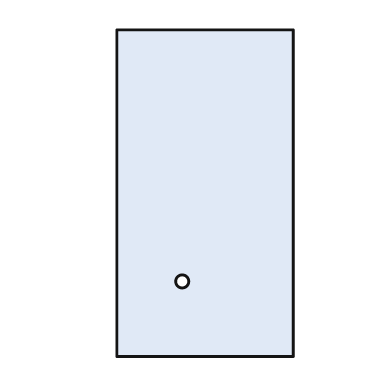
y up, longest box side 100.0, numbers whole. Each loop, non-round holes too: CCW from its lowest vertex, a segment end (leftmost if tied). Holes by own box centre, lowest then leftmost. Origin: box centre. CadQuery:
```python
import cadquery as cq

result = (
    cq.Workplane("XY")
    .moveTo(-27.0, -50.0)
    .lineTo(27.0, -50.0)
    .lineTo(27.0, 50.0)
    .lineTo(-27.0, 50.0)
    .close()
    .moveTo(-7.0, -27.0)
    .circle(2.0)
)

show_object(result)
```